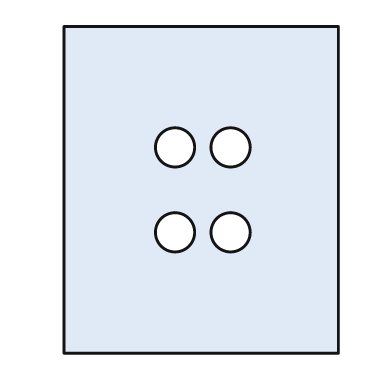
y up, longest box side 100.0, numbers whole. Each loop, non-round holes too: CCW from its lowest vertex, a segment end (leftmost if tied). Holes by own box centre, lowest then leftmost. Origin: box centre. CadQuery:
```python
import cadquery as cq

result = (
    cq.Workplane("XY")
    .moveTo(-42.0, -50.0)
    .lineTo(42.0, -50.0)
    .lineTo(42.0, 50.0)
    .lineTo(-42.0, 50.0)
    .close()
    .moveTo(-8.0, -13.0)
    .circle(6.0)
    .moveTo(9.0, -13.0)
    .circle(6.0)
    .moveTo(-8.0, 13.0)
    .circle(6.0)
    .moveTo(9.0, 13.0)
    .circle(6.0)
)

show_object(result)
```